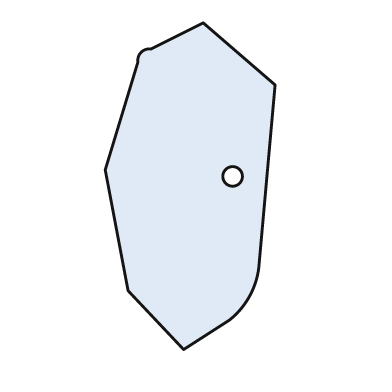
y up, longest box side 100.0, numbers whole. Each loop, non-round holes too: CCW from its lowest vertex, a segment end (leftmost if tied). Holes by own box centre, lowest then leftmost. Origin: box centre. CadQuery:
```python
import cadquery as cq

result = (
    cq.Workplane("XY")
    .moveTo(-2.0, -50.0)
    .lineTo(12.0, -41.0)
    .threePointArc((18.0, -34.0), (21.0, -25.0))
    .lineTo(26.0, 31.0)
    .lineTo(4.0, 50.0)
    .lineTo(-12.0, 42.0)
    .threePointArc((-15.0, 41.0), (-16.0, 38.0))
    .lineTo(-26.0, 5.0)
    .lineTo(-19.0, -32.0)
    .close()
    .moveTo(13.0, 3.0)
    .circle(3.0)
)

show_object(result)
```